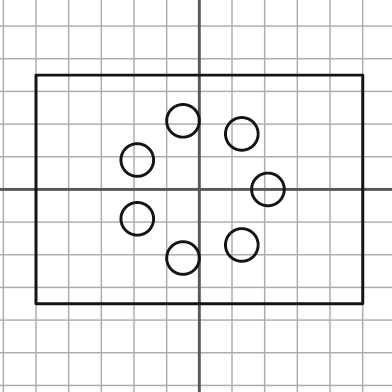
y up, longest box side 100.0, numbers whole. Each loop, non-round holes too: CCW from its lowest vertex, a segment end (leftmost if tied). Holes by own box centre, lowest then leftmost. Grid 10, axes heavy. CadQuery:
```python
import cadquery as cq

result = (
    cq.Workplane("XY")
    .moveTo(-50.0, -35.0)
    .lineTo(50.0, -35.0)
    .lineTo(50.0, 35.0)
    .lineTo(-50.0, 35.0)
    .close()
    .moveTo(-5.0, -21.0)
    .circle(5.0)
    .moveTo(13.0, -17.0)
    .circle(5.0)
    .moveTo(-19.0, -9.0)
    .circle(5.0)
    .moveTo(21.0, 0.0)
    .circle(5.0)
    .moveTo(-19.0, 9.0)
    .circle(5.0)
    .moveTo(13.0, 17.0)
    .circle(5.0)
    .moveTo(-5.0, 21.0)
    .circle(5.0)
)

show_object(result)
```